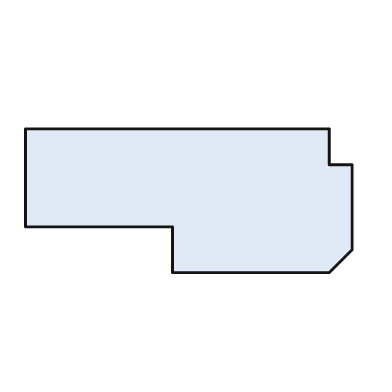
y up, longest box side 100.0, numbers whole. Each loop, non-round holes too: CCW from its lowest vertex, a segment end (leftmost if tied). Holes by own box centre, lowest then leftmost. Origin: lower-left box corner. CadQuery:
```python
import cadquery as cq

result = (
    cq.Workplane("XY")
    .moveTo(45.0, 0.0)
    .lineTo(93.0, 0.0)
    .lineTo(100.0, 7.0)
    .lineTo(100.0, 33.0)
    .lineTo(93.0, 33.0)
    .lineTo(93.0, 44.0)
    .lineTo(0.0, 44.0)
    .lineTo(0.0, 14.0)
    .lineTo(45.0, 14.0)
    .close()
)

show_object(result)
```